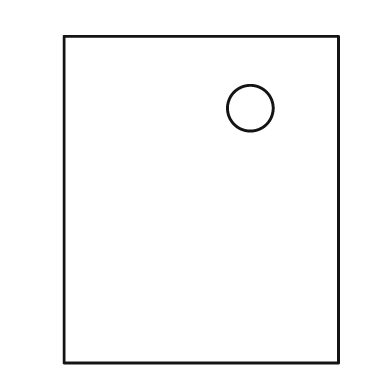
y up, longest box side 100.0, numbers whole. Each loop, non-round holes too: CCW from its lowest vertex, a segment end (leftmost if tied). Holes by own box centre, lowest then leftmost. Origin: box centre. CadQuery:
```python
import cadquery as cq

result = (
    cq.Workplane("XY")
    .moveTo(-42.0, -50.0)
    .lineTo(42.0, -50.0)
    .lineTo(42.0, 50.0)
    .lineTo(-42.0, 50.0)
    .close()
    .moveTo(15.0, 28.0)
    .circle(7.0)
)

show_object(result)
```